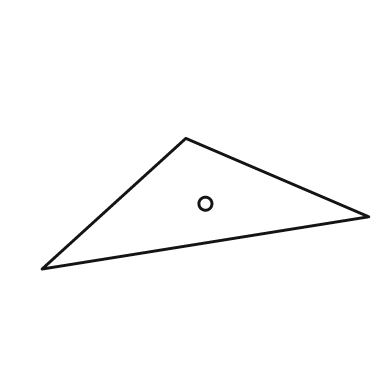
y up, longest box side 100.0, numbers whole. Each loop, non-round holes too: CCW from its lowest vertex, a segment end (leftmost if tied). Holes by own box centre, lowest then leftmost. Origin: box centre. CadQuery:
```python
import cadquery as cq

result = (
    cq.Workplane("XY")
    .moveTo(-50.0, -20.0)
    .lineTo(50.0, -4.0)
    .lineTo(-6.0, 20.0)
    .close()
    .moveTo(0.0, 0.0)
    .circle(2.0)
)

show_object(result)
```